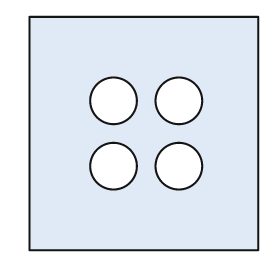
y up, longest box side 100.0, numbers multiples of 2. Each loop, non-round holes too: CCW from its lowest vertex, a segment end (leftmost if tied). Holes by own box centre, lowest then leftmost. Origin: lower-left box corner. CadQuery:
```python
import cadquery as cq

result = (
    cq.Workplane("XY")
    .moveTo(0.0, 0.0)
    .lineTo(98.0, 0.0)
    .lineTo(98.0, 100.0)
    .lineTo(0.0, 100.0)
    .close()
    .moveTo(36.0, 36.0)
    .circle(10.0)
    .moveTo(64.0, 36.0)
    .circle(10.0)
    .moveTo(36.0, 64.0)
    .circle(10.0)
    .moveTo(64.0, 64.0)
    .circle(10.0)
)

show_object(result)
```